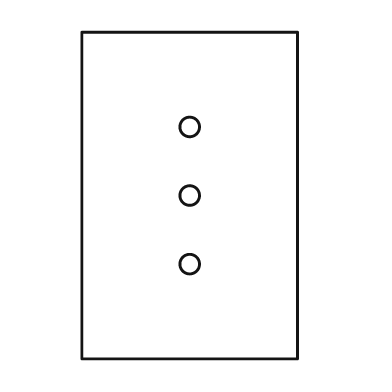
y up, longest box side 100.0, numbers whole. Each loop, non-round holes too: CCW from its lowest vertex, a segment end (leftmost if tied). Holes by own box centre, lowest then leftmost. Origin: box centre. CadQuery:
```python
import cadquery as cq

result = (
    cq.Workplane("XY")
    .moveTo(-33.0, -50.0)
    .lineTo(33.0, -50.0)
    .lineTo(33.0, 50.0)
    .lineTo(-33.0, 50.0)
    .close()
    .moveTo(0.0, -21.0)
    .circle(3.0)
    .moveTo(0.0, 0.0)
    .circle(3.0)
    .moveTo(0.0, 21.0)
    .circle(3.0)
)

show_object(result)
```